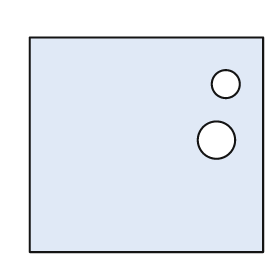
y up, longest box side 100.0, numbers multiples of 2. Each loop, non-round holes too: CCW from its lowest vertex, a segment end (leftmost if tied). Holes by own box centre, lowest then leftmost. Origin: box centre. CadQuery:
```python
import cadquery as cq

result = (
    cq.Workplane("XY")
    .moveTo(-50.0, -46.0)
    .lineTo(50.0, -46.0)
    .lineTo(50.0, 46.0)
    .lineTo(-50.0, 46.0)
    .close()
    .moveTo(30.0, 2.0)
    .circle(8.0)
    .moveTo(34.0, 26.0)
    .circle(6.0)
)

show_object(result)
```